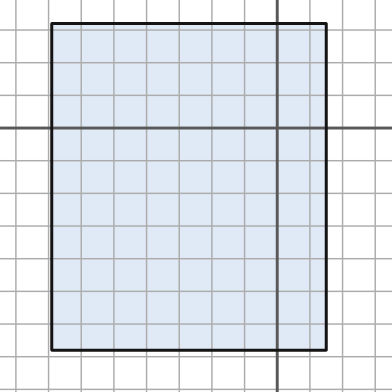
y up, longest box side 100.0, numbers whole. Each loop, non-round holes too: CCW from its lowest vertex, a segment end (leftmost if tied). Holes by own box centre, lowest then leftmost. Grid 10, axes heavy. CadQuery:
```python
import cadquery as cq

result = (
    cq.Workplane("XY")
    .moveTo(-69.0, -68.0)
    .lineTo(15.0, -68.0)
    .lineTo(15.0, 32.0)
    .lineTo(-69.0, 32.0)
    .close()
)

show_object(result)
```